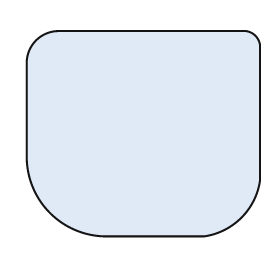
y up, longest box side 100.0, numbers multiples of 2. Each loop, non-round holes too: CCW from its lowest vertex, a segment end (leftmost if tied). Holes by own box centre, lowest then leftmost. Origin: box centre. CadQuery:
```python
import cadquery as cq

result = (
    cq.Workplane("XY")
    .moveTo(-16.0, -44.0)
    .lineTo(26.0, -44.0)
    .threePointArc((42.0, -36.0), (50.0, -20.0))
    .lineTo(50.0, 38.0)
    .threePointArc((48.0, 42.0), (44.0, 44.0))
    .lineTo(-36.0, 44.0)
    .threePointArc((-46.0, 40.0), (-50.0, 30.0))
    .lineTo(-50.0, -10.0)
    .threePointArc((-40.0, -34.0), (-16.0, -44.0))
    .close()
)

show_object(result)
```